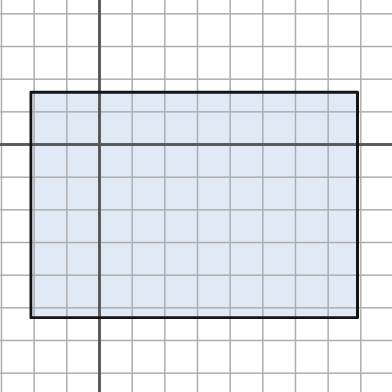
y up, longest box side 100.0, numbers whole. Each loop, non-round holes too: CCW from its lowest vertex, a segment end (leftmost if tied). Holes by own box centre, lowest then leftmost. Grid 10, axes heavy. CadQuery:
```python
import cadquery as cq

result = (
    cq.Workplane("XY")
    .moveTo(-21.0, -53.0)
    .lineTo(79.0, -53.0)
    .lineTo(79.0, 16.0)
    .lineTo(-21.0, 16.0)
    .close()
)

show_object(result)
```